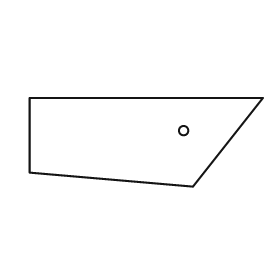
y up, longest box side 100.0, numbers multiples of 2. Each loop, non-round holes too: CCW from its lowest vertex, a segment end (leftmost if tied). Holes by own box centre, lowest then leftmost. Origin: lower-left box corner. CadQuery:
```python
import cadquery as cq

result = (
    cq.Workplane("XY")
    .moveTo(70.0, 0.0)
    .lineTo(100.0, 38.0)
    .lineTo(0.0, 38.0)
    .lineTo(0.0, 6.0)
    .close()
    .moveTo(66.0, 24.0)
    .circle(2.0)
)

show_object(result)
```